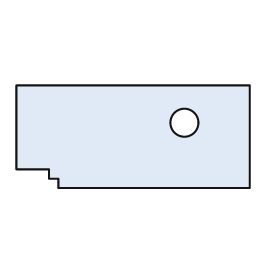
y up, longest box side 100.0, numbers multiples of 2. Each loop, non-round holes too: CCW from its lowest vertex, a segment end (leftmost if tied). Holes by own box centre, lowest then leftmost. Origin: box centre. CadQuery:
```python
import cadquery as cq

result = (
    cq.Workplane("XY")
    .moveTo(-32.0, -22.0)
    .lineTo(50.0, -22.0)
    .lineTo(50.0, 22.0)
    .lineTo(-50.0, 22.0)
    .lineTo(-50.0, -14.0)
    .lineTo(-36.0, -14.0)
    .lineTo(-36.0, -18.0)
    .lineTo(-32.0, -18.0)
    .close()
    .moveTo(22.0, 6.0)
    .circle(6.0)
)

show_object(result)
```